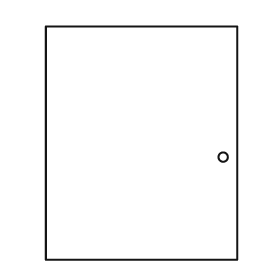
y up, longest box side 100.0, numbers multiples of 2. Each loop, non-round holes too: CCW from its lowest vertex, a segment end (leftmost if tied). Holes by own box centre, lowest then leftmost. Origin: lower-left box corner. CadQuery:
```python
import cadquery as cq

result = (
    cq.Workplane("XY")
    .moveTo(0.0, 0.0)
    .lineTo(82.0, 0.0)
    .lineTo(82.0, 100.0)
    .lineTo(0.0, 100.0)
    .close()
    .moveTo(76.0, 44.0)
    .circle(2.0)
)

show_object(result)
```